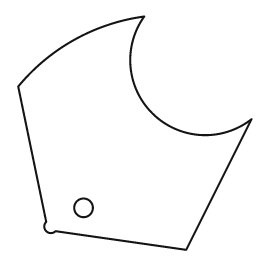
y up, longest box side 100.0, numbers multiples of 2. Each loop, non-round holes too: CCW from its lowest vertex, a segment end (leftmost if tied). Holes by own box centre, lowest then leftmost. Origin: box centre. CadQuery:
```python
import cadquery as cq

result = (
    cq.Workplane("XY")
    .moveTo(22.0, -50.0)
    .lineTo(50.0, 6.0)
    .threePointArc((8.0, 8.0), (4.0, 50.0))
    .threePointArc((-26.0, 40.0), (-50.0, 20.0))
    .lineTo(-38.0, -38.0)
    .threePointArc((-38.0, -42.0), (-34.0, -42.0))
    .close()
    .moveTo(-22.0, -32.0)
    .circle(4.0)
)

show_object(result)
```